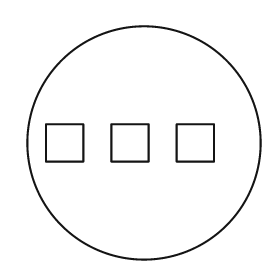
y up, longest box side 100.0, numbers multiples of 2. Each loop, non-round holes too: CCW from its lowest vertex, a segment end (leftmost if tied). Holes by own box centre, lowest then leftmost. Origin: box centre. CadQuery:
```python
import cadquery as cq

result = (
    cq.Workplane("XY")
    .moveTo(0.0, 0.0)
    .circle(50.0)
    .moveTo(-42.0, -8.0)
    .lineTo(-26.0, -8.0)
    .lineTo(-26.0, 8.0)
    .lineTo(-42.0, 8.0)
    .close()
    .moveTo(-14.0, -8.0)
    .lineTo(2.0, -8.0)
    .lineTo(2.0, 8.0)
    .lineTo(-14.0, 8.0)
    .close()
    .moveTo(14.0, -8.0)
    .lineTo(30.0, -8.0)
    .lineTo(30.0, 8.0)
    .lineTo(14.0, 8.0)
    .close()
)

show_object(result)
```